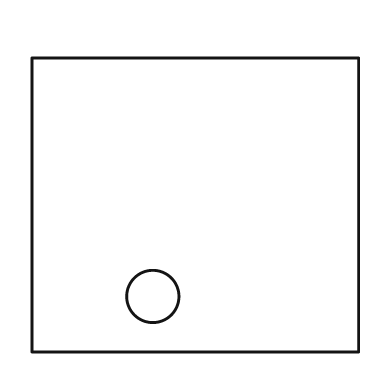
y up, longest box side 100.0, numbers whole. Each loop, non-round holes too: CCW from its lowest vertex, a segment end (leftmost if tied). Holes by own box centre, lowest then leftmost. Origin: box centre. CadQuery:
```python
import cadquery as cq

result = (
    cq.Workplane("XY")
    .moveTo(-50.0, -45.0)
    .lineTo(50.0, -45.0)
    .lineTo(50.0, 45.0)
    .lineTo(-50.0, 45.0)
    .close()
    .moveTo(-13.0, -28.0)
    .circle(8.0)
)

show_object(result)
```